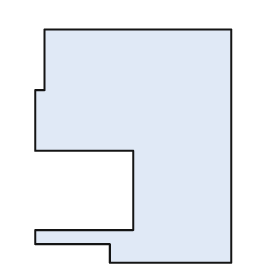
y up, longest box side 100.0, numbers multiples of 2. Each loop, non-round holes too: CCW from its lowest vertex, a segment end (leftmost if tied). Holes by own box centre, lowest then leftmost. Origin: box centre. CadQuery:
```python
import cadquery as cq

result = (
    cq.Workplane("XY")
    .moveTo(-10.0, -50.0)
    .lineTo(42.0, -50.0)
    .lineTo(42.0, 50.0)
    .lineTo(-38.0, 50.0)
    .lineTo(-38.0, 24.0)
    .lineTo(-42.0, 24.0)
    .lineTo(-42.0, -2.0)
    .lineTo(0.0, -2.0)
    .lineTo(0.0, -36.0)
    .lineTo(-42.0, -36.0)
    .lineTo(-42.0, -42.0)
    .lineTo(-10.0, -42.0)
    .close()
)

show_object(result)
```